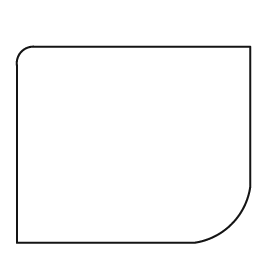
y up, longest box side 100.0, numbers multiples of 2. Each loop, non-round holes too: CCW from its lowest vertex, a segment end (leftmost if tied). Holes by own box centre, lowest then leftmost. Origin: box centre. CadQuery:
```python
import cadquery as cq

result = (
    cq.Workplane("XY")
    .moveTo(-50.0, -42.0)
    .lineTo(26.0, -42.0)
    .threePointArc((42.0, -34.0), (50.0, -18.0))
    .lineTo(50.0, 42.0)
    .lineTo(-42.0, 42.0)
    .threePointArc((-48.0, 40.0), (-50.0, 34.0))
    .close()
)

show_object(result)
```